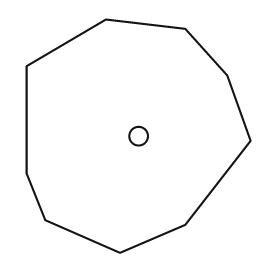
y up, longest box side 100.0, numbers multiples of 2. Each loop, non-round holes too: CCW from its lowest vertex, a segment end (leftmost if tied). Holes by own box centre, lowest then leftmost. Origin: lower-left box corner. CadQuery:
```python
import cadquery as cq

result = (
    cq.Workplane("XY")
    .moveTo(40.0, 0.0)
    .lineTo(68.0, 12.0)
    .lineTo(96.0, 48.0)
    .lineTo(86.0, 76.0)
    .lineTo(68.0, 96.0)
    .lineTo(34.0, 100.0)
    .lineTo(0.0, 80.0)
    .lineTo(0.0, 34.0)
    .lineTo(8.0, 14.0)
    .close()
    .moveTo(48.0, 50.0)
    .circle(4.0)
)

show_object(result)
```